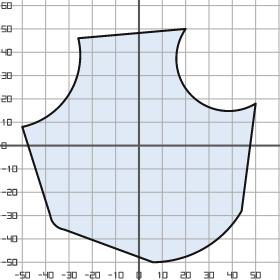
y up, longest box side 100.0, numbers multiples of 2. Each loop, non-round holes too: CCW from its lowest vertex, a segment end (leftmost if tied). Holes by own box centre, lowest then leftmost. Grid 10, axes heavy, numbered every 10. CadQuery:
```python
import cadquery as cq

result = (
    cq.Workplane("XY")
    .moveTo(6.0, -50.0)
    .threePointArc((28.0, -44.0), (44.0, -28.0))
    .lineTo(50.0, 18.0)
    .threePointArc((22.0, 22.0), (20.0, 50.0))
    .lineTo(-26.0, 46.0)
    .threePointArc((-30.0, 22.0), (-50.0, 8.0))
    .lineTo(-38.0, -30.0)
    .threePointArc((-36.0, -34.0), (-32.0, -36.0))
    .close()
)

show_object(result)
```